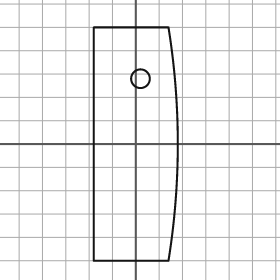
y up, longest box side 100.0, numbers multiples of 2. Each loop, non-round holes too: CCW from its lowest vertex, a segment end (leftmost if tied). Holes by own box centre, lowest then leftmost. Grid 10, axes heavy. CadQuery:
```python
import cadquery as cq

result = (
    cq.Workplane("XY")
    .moveTo(-18.0, -50.0)
    .lineTo(14.0, -50.0)
    .threePointArc((18.0, 0.0), (14.0, 50.0))
    .lineTo(-18.0, 50.0)
    .close()
    .moveTo(2.0, 28.0)
    .circle(4.0)
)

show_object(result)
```